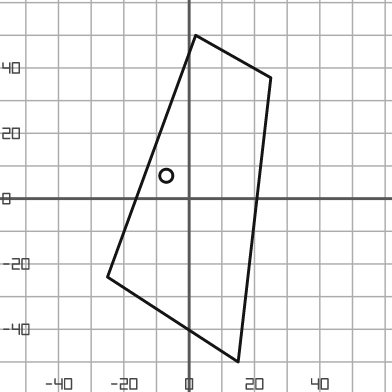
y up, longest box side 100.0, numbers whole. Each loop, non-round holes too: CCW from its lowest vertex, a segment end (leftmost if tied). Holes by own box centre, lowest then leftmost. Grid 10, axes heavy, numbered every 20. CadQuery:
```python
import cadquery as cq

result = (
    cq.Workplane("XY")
    .moveTo(15.0, -50.0)
    .lineTo(25.0, 37.0)
    .lineTo(2.0, 50.0)
    .lineTo(-25.0, -24.0)
    .close()
    .moveTo(-7.0, 7.0)
    .circle(2.0)
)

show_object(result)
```